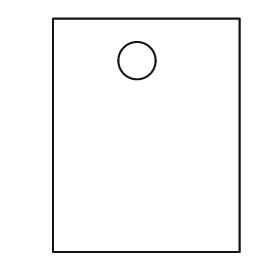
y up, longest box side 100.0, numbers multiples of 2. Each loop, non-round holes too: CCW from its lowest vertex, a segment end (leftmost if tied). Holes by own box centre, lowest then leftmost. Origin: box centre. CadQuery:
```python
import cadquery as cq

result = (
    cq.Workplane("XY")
    .moveTo(-40.0, -50.0)
    .lineTo(40.0, -50.0)
    .lineTo(40.0, 50.0)
    .lineTo(-40.0, 50.0)
    .close()
    .moveTo(-4.0, 32.0)
    .circle(8.0)
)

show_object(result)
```